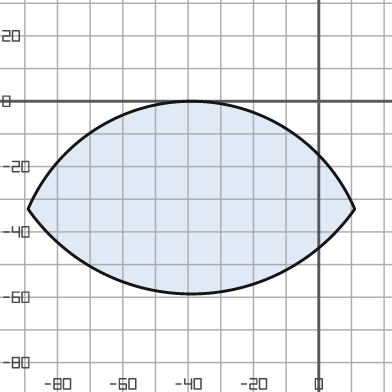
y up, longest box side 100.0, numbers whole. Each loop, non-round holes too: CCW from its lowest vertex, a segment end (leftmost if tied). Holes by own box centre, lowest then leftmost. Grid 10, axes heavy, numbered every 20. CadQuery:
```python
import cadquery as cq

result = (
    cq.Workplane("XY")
    .moveTo(-89.0, -33.0)
    .threePointArc((-39.0, -59.0), (11.0, -33.0))
    .threePointArc((-39.0, 0.0), (-89.0, -33.0))
    .close()
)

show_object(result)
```